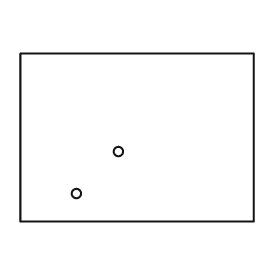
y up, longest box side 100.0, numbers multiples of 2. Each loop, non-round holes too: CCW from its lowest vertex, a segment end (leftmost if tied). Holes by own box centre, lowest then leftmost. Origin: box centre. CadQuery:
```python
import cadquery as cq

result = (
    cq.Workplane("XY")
    .moveTo(-50.0, -36.0)
    .lineTo(50.0, -36.0)
    .lineTo(50.0, 36.0)
    .lineTo(-50.0, 36.0)
    .close()
    .moveTo(-26.0, -24.0)
    .circle(2.0)
    .moveTo(-8.0, -6.0)
    .circle(2.0)
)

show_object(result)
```